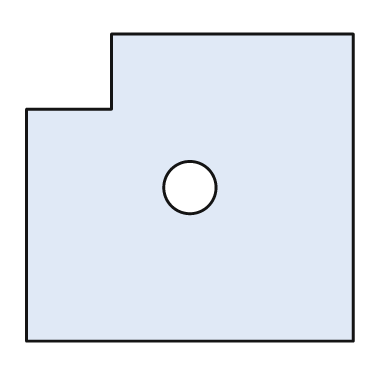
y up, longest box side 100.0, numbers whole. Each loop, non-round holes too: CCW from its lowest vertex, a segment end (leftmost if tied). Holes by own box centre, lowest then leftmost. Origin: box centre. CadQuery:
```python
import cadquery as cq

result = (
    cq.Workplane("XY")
    .moveTo(-50.0, -47.0)
    .lineTo(50.0, -47.0)
    .lineTo(50.0, 47.0)
    .lineTo(-24.0, 47.0)
    .lineTo(-24.0, 24.0)
    .lineTo(-50.0, 24.0)
    .close()
    .moveTo(0.0, 0.0)
    .circle(8.0)
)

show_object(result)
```